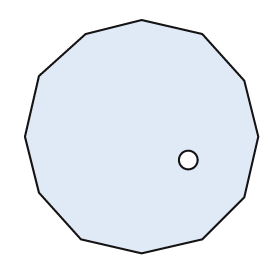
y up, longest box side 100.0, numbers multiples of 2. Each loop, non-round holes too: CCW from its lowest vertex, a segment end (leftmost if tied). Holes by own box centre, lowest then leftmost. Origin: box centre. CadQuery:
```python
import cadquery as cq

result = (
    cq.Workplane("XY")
    .moveTo(0.0, -50.0)
    .lineTo(26.0, -44.0)
    .lineTo(44.0, -26.0)
    .lineTo(50.0, 0.0)
    .lineTo(44.0, 24.0)
    .lineTo(26.0, 44.0)
    .lineTo(0.0, 50.0)
    .lineTo(-24.0, 44.0)
    .lineTo(-44.0, 26.0)
    .lineTo(-50.0, 0.0)
    .lineTo(-44.0, -24.0)
    .lineTo(-26.0, -44.0)
    .close()
    .moveTo(20.0, -10.0)
    .circle(4.0)
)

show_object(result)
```